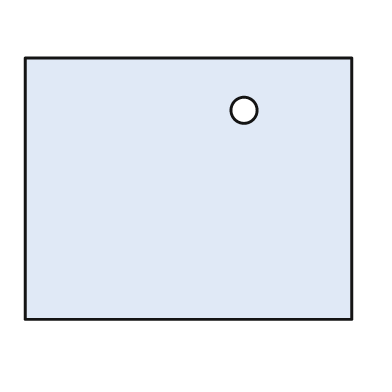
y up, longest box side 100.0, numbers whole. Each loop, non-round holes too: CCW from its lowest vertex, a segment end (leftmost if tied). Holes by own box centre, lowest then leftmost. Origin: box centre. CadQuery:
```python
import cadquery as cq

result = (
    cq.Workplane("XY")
    .moveTo(-50.0, -40.0)
    .lineTo(50.0, -40.0)
    .lineTo(50.0, 40.0)
    .lineTo(-50.0, 40.0)
    .close()
    .moveTo(17.0, 24.0)
    .circle(4.0)
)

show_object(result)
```